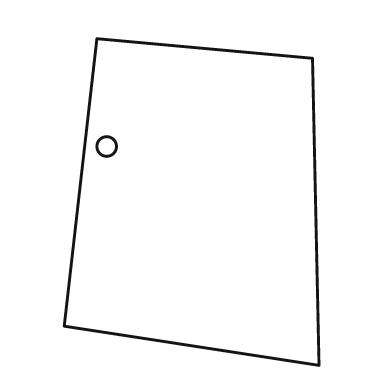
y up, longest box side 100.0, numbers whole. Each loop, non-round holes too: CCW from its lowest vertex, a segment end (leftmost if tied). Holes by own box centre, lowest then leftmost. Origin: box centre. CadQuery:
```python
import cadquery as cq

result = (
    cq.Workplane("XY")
    .moveTo(39.0, -50.0)
    .lineTo(37.0, 44.0)
    .lineTo(-29.0, 50.0)
    .lineTo(-39.0, -38.0)
    .close()
    .moveTo(-26.0, 17.0)
    .circle(3.0)
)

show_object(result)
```